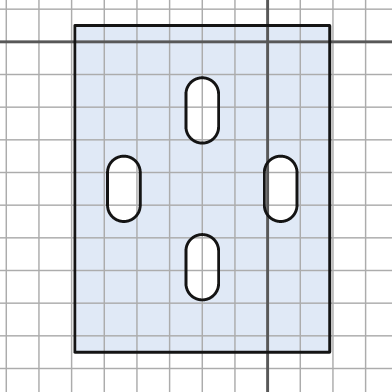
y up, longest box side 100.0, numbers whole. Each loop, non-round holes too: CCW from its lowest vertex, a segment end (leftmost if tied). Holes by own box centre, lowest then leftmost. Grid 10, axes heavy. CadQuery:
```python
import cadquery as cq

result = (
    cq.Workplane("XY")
    .moveTo(-59.0, -95.0)
    .lineTo(19.0, -95.0)
    .lineTo(19.0, 5.0)
    .lineTo(-59.0, 5.0)
    .close()
    .moveTo(-25.0, -74.0)
    .threePointArc((-20.0, -79.0), (-15.0, -74.0))
    .lineTo(-15.0, -64.0)
    .threePointArc((-20.0, -59.0), (-25.0, -64.0))
    .close()
    .moveTo(-49.0, -50.0)
    .threePointArc((-44.0, -55.0), (-39.0, -50.0))
    .lineTo(-39.0, -40.0)
    .threePointArc((-44.0, -35.0), (-49.0, -40.0))
    .close()
    .moveTo(-1.0, -50.0)
    .threePointArc((4.0, -55.0), (9.0, -50.0))
    .lineTo(9.0, -40.0)
    .threePointArc((4.0, -35.0), (-1.0, -40.0))
    .close()
    .moveTo(-25.0, -26.0)
    .threePointArc((-20.0, -31.0), (-15.0, -26.0))
    .lineTo(-15.0, -16.0)
    .threePointArc((-20.0, -11.0), (-25.0, -16.0))
    .close()
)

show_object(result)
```